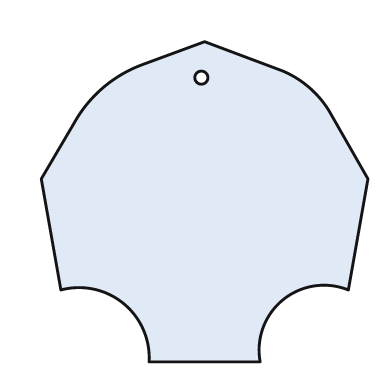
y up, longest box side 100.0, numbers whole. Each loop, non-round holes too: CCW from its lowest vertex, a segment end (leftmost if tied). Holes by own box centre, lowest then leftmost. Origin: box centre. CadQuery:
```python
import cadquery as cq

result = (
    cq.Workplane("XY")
    .moveTo(-17.0, -49.0)
    .lineTo(17.0, -49.0)
    .threePointArc((24.0, -30.0), (44.0, -27.0))
    .lineTo(50.0, 7.0)
    .lineTo(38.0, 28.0)
    .threePointArc((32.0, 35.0), (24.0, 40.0))
    .lineTo(0.0, 49.0)
    .lineTo(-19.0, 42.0)
    .threePointArc((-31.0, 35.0), (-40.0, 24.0))
    .lineTo(-50.0, 7.0)
    .lineTo(-44.0, -27.0)
    .threePointArc((-25.0, -31.0), (-17.0, -49.0))
    .close()
    .moveTo(-1.0, 38.0)
    .circle(2.0)
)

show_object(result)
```